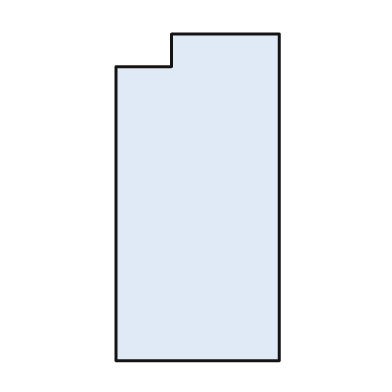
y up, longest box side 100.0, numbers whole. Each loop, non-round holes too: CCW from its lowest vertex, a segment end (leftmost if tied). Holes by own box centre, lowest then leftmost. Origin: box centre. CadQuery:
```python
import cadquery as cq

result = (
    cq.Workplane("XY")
    .moveTo(-25.0, -50.0)
    .lineTo(25.0, -50.0)
    .lineTo(25.0, 50.0)
    .lineTo(-8.0, 50.0)
    .lineTo(-8.0, 40.0)
    .lineTo(-25.0, 40.0)
    .close()
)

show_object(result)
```